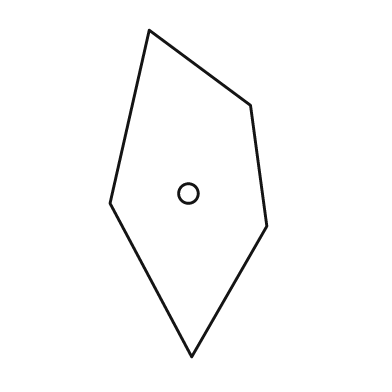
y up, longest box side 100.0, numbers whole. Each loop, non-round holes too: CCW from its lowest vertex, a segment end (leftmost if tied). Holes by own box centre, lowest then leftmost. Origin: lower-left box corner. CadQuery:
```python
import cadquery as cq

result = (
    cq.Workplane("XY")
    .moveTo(25.0, 0.0)
    .lineTo(48.0, 40.0)
    .lineTo(43.0, 77.0)
    .lineTo(12.0, 100.0)
    .lineTo(0.0, 47.0)
    .close()
    .moveTo(24.0, 50.0)
    .circle(3.0)
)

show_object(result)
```